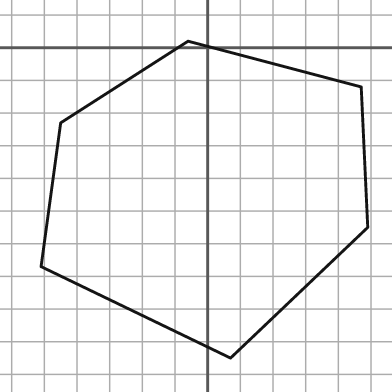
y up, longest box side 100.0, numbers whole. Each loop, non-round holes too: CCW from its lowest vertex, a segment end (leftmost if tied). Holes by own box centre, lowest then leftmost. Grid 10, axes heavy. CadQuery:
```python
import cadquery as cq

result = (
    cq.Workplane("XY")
    .moveTo(7.0, -95.0)
    .lineTo(49.0, -55.0)
    .lineTo(47.0, -12.0)
    .lineTo(-6.0, 2.0)
    .lineTo(-45.0, -23.0)
    .lineTo(-51.0, -67.0)
    .close()
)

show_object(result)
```